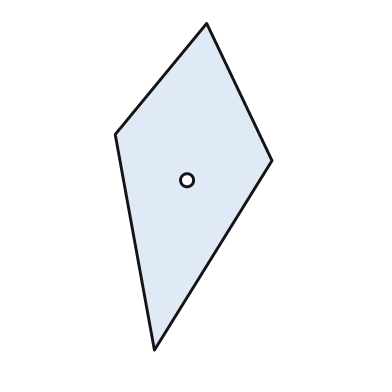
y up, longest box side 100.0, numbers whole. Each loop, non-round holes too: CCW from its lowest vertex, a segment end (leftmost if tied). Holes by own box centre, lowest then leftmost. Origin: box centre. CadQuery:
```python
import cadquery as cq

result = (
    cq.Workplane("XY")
    .moveTo(-12.0, -50.0)
    .lineTo(24.0, 8.0)
    .lineTo(4.0, 50.0)
    .lineTo(-24.0, 16.0)
    .close()
    .moveTo(-2.0, 2.0)
    .circle(2.0)
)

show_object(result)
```